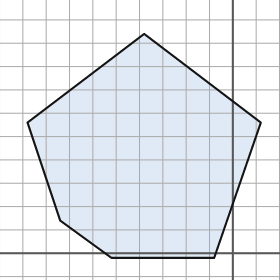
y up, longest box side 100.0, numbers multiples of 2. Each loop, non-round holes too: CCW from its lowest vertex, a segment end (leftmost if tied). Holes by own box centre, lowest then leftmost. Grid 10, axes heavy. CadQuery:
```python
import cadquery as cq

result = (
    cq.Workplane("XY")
    .moveTo(-52.0, -2.0)
    .lineTo(-8.0, -2.0)
    .lineTo(12.0, 56.0)
    .lineTo(-38.0, 94.0)
    .lineTo(-88.0, 56.0)
    .lineTo(-74.0, 14.0)
    .close()
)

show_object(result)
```